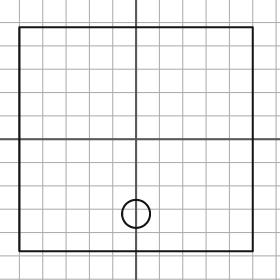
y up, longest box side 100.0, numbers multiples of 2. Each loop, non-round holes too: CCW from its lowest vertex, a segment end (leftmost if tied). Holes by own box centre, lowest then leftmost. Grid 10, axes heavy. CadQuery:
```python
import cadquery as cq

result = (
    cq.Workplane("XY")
    .moveTo(-50.0, -48.0)
    .lineTo(50.0, -48.0)
    .lineTo(50.0, 48.0)
    .lineTo(-50.0, 48.0)
    .close()
    .moveTo(0.0, -32.0)
    .circle(6.0)
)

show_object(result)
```